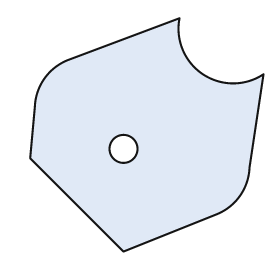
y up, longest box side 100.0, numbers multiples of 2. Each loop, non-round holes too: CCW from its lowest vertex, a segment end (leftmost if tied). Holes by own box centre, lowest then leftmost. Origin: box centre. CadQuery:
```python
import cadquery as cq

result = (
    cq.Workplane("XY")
    .moveTo(-10.0, -50.0)
    .lineTo(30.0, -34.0)
    .threePointArc((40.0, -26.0), (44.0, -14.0))
    .lineTo(50.0, 26.0)
    .threePointArc((24.0, 26.0), (14.0, 50.0))
    .lineTo(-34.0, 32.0)
    .threePointArc((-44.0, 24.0), (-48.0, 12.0))
    .lineTo(-50.0, -10.0)
    .close()
    .moveTo(-10.0, -6.0)
    .circle(6.0)
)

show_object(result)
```